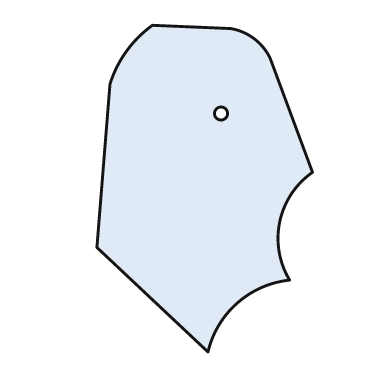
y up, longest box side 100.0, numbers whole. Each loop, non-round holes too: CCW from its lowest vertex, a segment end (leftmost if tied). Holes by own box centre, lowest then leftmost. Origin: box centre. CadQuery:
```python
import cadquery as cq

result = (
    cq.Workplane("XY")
    .moveTo(1.0, -50.0)
    .threePointArc((10.0, -35.0), (26.0, -28.0))
    .threePointArc((23.0, -10.0), (33.0, 5.0))
    .lineTo(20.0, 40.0)
    .threePointArc((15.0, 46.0), (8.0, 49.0))
    .lineTo(-16.0, 50.0)
    .threePointArc((-24.0, 42.0), (-29.0, 32.0))
    .lineTo(-33.0, -18.0)
    .close()
    .moveTo(5.0, 23.0)
    .circle(2.0)
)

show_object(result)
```